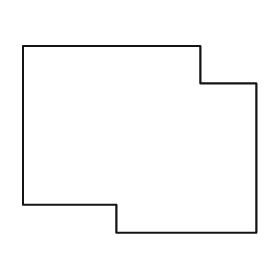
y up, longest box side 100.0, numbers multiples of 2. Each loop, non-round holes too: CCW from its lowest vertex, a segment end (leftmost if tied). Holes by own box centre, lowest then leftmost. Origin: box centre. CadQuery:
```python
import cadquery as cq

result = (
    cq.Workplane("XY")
    .moveTo(-10.0, -40.0)
    .lineTo(50.0, -40.0)
    .lineTo(50.0, 24.0)
    .lineTo(26.0, 24.0)
    .lineTo(26.0, 40.0)
    .lineTo(-50.0, 40.0)
    .lineTo(-50.0, -28.0)
    .lineTo(-10.0, -28.0)
    .close()
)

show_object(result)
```